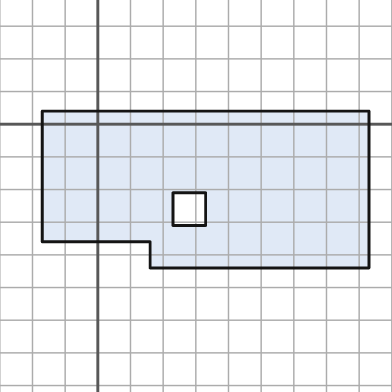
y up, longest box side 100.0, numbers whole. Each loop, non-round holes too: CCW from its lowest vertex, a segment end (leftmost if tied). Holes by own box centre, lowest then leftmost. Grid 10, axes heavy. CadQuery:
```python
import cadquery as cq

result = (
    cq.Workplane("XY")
    .moveTo(16.0, -44.0)
    .lineTo(83.0, -44.0)
    .lineTo(83.0, 4.0)
    .lineTo(-17.0, 4.0)
    .lineTo(-17.0, -36.0)
    .lineTo(16.0, -36.0)
    .close()
    .moveTo(23.0, -31.0)
    .lineTo(33.0, -31.0)
    .lineTo(33.0, -21.0)
    .lineTo(23.0, -21.0)
    .close()
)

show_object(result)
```